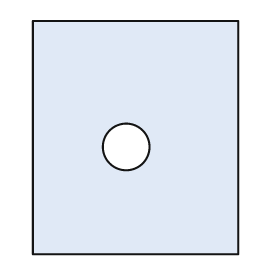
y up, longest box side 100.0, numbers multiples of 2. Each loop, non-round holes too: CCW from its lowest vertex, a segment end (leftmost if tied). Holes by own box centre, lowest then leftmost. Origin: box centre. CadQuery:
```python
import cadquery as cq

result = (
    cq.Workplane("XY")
    .moveTo(-44.0, -50.0)
    .lineTo(44.0, -50.0)
    .lineTo(44.0, 50.0)
    .lineTo(-44.0, 50.0)
    .close()
    .moveTo(-4.0, -4.0)
    .circle(10.0)
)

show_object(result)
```